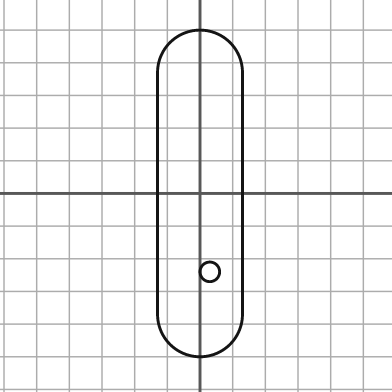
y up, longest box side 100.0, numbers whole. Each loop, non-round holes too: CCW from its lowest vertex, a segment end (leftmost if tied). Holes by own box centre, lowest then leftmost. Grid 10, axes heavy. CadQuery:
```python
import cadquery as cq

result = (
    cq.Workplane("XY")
    .moveTo(-13.0, -37.0)
    .threePointArc((0.0, -50.0), (13.0, -37.0))
    .lineTo(13.0, 37.0)
    .threePointArc((0.0, 50.0), (-13.0, 37.0))
    .close()
    .moveTo(3.0, -24.0)
    .circle(3.0)
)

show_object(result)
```